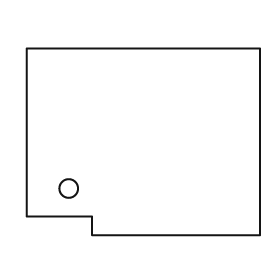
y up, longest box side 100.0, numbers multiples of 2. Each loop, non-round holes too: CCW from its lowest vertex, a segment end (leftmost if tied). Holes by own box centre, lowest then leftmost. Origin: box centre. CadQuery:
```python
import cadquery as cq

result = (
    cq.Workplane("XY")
    .moveTo(-22.0, -40.0)
    .lineTo(50.0, -40.0)
    .lineTo(50.0, 40.0)
    .lineTo(-50.0, 40.0)
    .lineTo(-50.0, -32.0)
    .lineTo(-22.0, -32.0)
    .close()
    .moveTo(-32.0, -20.0)
    .circle(4.0)
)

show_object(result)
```